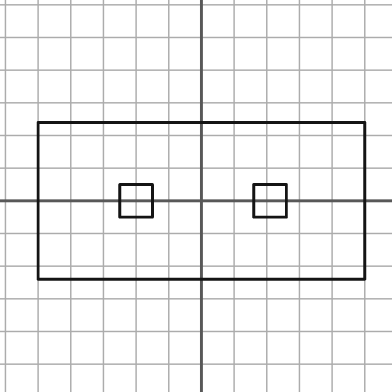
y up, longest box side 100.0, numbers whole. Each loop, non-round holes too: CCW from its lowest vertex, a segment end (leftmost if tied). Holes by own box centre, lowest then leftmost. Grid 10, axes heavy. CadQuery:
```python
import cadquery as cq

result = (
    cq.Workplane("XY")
    .moveTo(-50.0, -24.0)
    .lineTo(50.0, -24.0)
    .lineTo(50.0, 24.0)
    .lineTo(-50.0, 24.0)
    .close()
    .moveTo(-25.0, -5.0)
    .lineTo(-15.0, -5.0)
    .lineTo(-15.0, 5.0)
    .lineTo(-25.0, 5.0)
    .close()
    .moveTo(16.0, -5.0)
    .lineTo(26.0, -5.0)
    .lineTo(26.0, 5.0)
    .lineTo(16.0, 5.0)
    .close()
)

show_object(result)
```